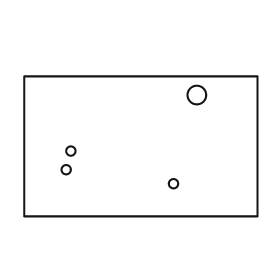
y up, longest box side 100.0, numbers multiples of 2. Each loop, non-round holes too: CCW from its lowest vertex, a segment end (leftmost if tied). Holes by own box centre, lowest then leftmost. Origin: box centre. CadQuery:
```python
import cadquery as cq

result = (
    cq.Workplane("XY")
    .moveTo(-50.0, -30.0)
    .lineTo(50.0, -30.0)
    .lineTo(50.0, 30.0)
    .lineTo(-50.0, 30.0)
    .close()
    .moveTo(14.0, -16.0)
    .circle(2.0)
    .moveTo(-32.0, -10.0)
    .circle(2.0)
    .moveTo(-30.0, -2.0)
    .circle(2.0)
    .moveTo(24.0, 22.0)
    .circle(4.0)
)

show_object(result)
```